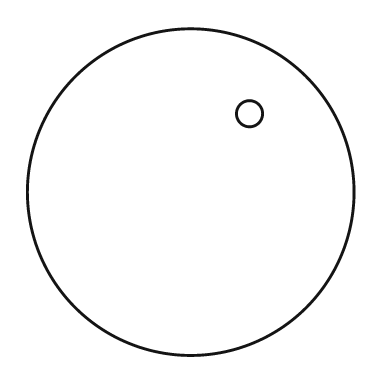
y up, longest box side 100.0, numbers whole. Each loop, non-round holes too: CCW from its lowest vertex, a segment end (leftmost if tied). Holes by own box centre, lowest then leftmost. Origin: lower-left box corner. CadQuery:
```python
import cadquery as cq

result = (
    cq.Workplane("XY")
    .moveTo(50.0, 50.0)
    .circle(50.0)
    .moveTo(68.0, 74.0)
    .circle(4.0)
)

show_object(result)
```